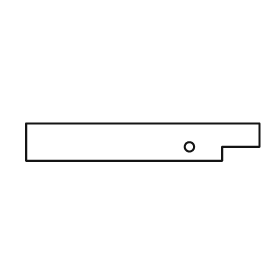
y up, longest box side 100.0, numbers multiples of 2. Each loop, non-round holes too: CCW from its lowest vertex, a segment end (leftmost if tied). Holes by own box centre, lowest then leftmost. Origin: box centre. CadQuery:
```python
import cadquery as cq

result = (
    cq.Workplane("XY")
    .moveTo(-50.0, -8.0)
    .lineTo(34.0, -8.0)
    .lineTo(34.0, -2.0)
    .lineTo(50.0, -2.0)
    .lineTo(50.0, 8.0)
    .lineTo(-50.0, 8.0)
    .close()
    .moveTo(20.0, -2.0)
    .circle(2.0)
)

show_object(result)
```